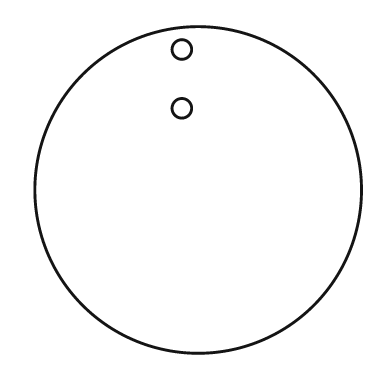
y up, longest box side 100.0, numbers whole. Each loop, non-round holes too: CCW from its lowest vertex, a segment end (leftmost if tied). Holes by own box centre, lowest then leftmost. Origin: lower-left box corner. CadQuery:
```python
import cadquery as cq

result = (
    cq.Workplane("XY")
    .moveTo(50.0, 50.0)
    .circle(50.0)
    .moveTo(45.0, 75.0)
    .circle(3.0)
    .moveTo(45.0, 93.0)
    .circle(3.0)
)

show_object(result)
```